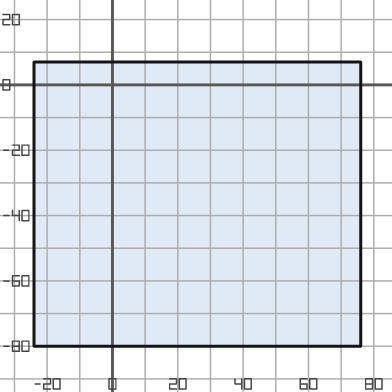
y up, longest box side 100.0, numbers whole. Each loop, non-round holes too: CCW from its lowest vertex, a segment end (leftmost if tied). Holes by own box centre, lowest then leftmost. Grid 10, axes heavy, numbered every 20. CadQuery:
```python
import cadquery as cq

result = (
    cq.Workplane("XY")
    .moveTo(-24.0, -80.0)
    .lineTo(76.0, -80.0)
    .lineTo(76.0, 7.0)
    .lineTo(-24.0, 7.0)
    .close()
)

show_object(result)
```